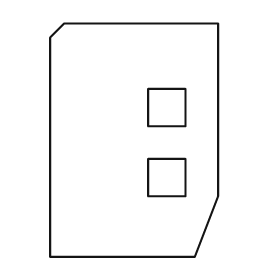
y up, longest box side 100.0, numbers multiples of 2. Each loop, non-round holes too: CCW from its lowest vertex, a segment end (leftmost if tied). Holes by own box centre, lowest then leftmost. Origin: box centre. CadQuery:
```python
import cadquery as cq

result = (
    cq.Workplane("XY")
    .moveTo(-36.0, -50.0)
    .lineTo(26.0, -50.0)
    .lineTo(36.0, -24.0)
    .lineTo(36.0, 50.0)
    .lineTo(-30.0, 50.0)
    .lineTo(-36.0, 44.0)
    .close()
    .moveTo(6.0, -24.0)
    .lineTo(22.0, -24.0)
    .lineTo(22.0, -8.0)
    .lineTo(6.0, -8.0)
    .close()
    .moveTo(6.0, 6.0)
    .lineTo(22.0, 6.0)
    .lineTo(22.0, 22.0)
    .lineTo(6.0, 22.0)
    .close()
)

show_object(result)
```